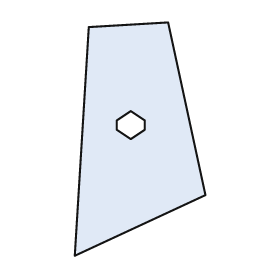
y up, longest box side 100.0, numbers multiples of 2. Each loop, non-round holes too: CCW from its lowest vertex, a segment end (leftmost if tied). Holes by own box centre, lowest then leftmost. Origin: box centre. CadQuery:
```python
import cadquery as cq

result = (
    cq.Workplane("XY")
    .moveTo(-28.0, -50.0)
    .lineTo(28.0, -24.0)
    .lineTo(12.0, 50.0)
    .lineTo(-22.0, 48.0)
    .close()
    .moveTo(-4.0, 0.0)
    .lineTo(2.0, 4.0)
    .lineTo(2.0, 8.0)
    .lineTo(-4.0, 12.0)
    .lineTo(-10.0, 8.0)
    .lineTo(-10.0, 4.0)
    .close()
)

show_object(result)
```